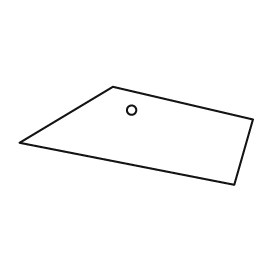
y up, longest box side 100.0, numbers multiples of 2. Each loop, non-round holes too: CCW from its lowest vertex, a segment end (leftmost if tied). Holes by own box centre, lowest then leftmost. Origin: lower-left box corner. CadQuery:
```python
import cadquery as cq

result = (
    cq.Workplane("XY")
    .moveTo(92.0, 0.0)
    .lineTo(100.0, 28.0)
    .lineTo(40.0, 42.0)
    .lineTo(0.0, 18.0)
    .close()
    .moveTo(48.0, 32.0)
    .circle(2.0)
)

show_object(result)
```